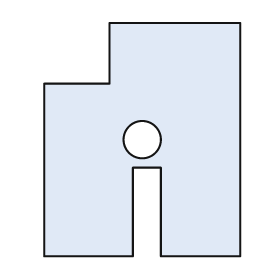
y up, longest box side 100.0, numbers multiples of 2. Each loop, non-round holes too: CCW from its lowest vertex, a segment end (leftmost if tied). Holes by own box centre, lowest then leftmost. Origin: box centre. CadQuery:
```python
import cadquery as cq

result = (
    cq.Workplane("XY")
    .moveTo(-42.0, -50.0)
    .lineTo(-4.0, -50.0)
    .lineTo(-4.0, -12.0)
    .lineTo(8.0, -12.0)
    .lineTo(8.0, -50.0)
    .lineTo(42.0, -50.0)
    .lineTo(42.0, 50.0)
    .lineTo(-14.0, 50.0)
    .lineTo(-14.0, 24.0)
    .lineTo(-42.0, 24.0)
    .close()
    .moveTo(0.0, 0.0)
    .circle(8.0)
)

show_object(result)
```